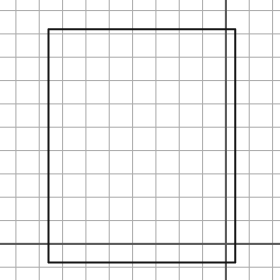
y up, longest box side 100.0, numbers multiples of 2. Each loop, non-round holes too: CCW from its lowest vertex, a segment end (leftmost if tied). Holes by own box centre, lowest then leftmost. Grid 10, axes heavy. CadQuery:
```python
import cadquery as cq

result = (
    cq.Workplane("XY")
    .moveTo(-76.0, -8.0)
    .lineTo(4.0, -8.0)
    .lineTo(4.0, 92.0)
    .lineTo(-76.0, 92.0)
    .close()
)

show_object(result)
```